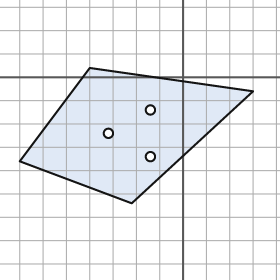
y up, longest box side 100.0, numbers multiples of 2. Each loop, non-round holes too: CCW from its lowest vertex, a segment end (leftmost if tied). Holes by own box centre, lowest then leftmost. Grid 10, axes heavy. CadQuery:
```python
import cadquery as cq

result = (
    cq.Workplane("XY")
    .moveTo(-22.0, -54.0)
    .lineTo(30.0, -6.0)
    .lineTo(-40.0, 4.0)
    .lineTo(-70.0, -36.0)
    .close()
    .moveTo(-14.0, -34.0)
    .circle(2.0)
    .moveTo(-32.0, -24.0)
    .circle(2.0)
    .moveTo(-14.0, -14.0)
    .circle(2.0)
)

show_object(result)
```